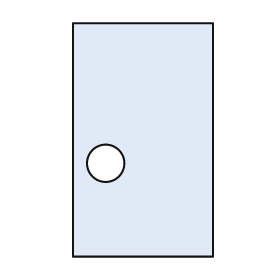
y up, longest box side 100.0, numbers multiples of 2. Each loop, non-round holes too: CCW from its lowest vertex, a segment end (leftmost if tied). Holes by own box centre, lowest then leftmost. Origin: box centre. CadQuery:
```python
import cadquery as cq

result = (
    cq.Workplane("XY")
    .moveTo(-30.0, -50.0)
    .lineTo(30.0, -50.0)
    .lineTo(30.0, 50.0)
    .lineTo(-30.0, 50.0)
    .close()
    .moveTo(-16.0, -10.0)
    .circle(8.0)
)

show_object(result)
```